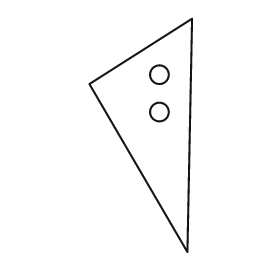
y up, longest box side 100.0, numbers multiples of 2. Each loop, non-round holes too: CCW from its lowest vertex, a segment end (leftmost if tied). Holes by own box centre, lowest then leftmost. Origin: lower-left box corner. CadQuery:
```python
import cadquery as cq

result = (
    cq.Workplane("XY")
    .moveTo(42.0, 0.0)
    .lineTo(44.0, 100.0)
    .lineTo(0.0, 72.0)
    .close()
    .moveTo(30.0, 60.0)
    .circle(4.0)
    .moveTo(30.0, 76.0)
    .circle(4.0)
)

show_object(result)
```